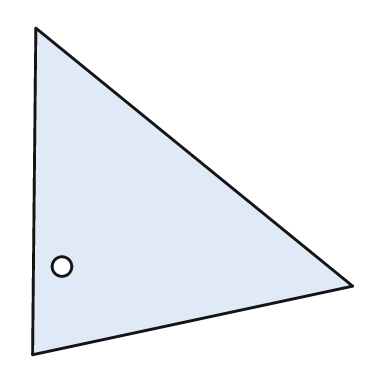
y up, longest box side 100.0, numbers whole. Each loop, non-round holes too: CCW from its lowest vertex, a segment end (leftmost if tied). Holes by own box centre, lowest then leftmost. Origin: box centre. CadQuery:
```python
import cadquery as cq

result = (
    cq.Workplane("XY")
    .moveTo(-49.0, -50.0)
    .lineTo(49.0, -29.0)
    .lineTo(-48.0, 50.0)
    .close()
    .moveTo(-40.0, -23.0)
    .circle(3.0)
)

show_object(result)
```